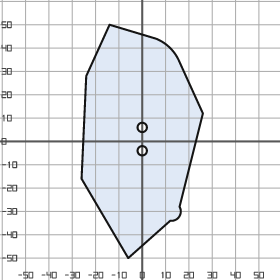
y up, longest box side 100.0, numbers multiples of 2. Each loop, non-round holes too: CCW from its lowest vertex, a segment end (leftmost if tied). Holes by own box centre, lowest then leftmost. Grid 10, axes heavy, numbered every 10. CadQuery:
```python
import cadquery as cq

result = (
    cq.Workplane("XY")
    .moveTo(-6.0, -50.0)
    .lineTo(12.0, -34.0)
    .threePointArc((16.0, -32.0), (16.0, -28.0))
    .lineTo(26.0, 12.0)
    .lineTo(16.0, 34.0)
    .threePointArc((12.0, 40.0), (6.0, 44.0))
    .lineTo(-14.0, 50.0)
    .lineTo(-24.0, 28.0)
    .lineTo(-26.0, -16.0)
    .close()
    .moveTo(0.0, -4.0)
    .circle(2.0)
    .moveTo(0.0, 6.0)
    .circle(2.0)
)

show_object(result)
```